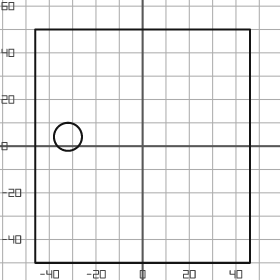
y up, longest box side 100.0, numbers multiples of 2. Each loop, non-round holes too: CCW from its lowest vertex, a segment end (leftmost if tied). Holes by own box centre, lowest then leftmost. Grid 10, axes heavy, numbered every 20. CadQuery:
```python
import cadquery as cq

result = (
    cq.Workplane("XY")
    .moveTo(-46.0, -50.0)
    .lineTo(46.0, -50.0)
    .lineTo(46.0, 50.0)
    .lineTo(-46.0, 50.0)
    .close()
    .moveTo(-32.0, 4.0)
    .circle(6.0)
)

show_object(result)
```